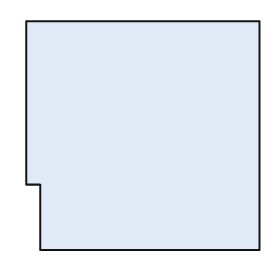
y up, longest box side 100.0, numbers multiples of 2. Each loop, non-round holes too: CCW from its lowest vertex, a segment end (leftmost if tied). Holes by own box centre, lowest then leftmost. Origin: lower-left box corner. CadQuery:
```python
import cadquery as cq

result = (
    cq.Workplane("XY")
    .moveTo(6.0, 0.0)
    .lineTo(100.0, 0.0)
    .lineTo(100.0, 98.0)
    .lineTo(0.0, 98.0)
    .lineTo(0.0, 28.0)
    .lineTo(6.0, 28.0)
    .close()
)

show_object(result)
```